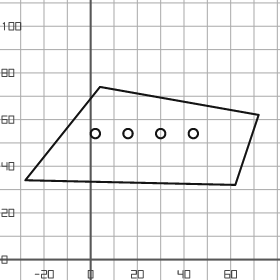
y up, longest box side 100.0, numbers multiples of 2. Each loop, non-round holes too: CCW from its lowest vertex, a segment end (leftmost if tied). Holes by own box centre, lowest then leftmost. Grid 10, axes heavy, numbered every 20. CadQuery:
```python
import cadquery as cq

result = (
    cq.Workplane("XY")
    .moveTo(62.0, 32.0)
    .lineTo(72.0, 62.0)
    .lineTo(4.0, 74.0)
    .lineTo(-28.0, 34.0)
    .close()
    .moveTo(2.0, 54.0)
    .circle(2.0)
    .moveTo(16.0, 54.0)
    .circle(2.0)
    .moveTo(30.0, 54.0)
    .circle(2.0)
    .moveTo(44.0, 54.0)
    .circle(2.0)
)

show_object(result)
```